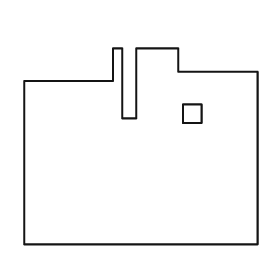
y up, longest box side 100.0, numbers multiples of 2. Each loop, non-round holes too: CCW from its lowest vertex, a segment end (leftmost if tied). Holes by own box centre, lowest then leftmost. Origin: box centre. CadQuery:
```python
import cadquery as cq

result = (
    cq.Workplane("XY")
    .moveTo(-50.0, -42.0)
    .lineTo(50.0, -42.0)
    .lineTo(50.0, 32.0)
    .lineTo(16.0, 32.0)
    .lineTo(16.0, 42.0)
    .lineTo(-2.0, 42.0)
    .lineTo(-2.0, 12.0)
    .lineTo(-8.0, 12.0)
    .lineTo(-8.0, 42.0)
    .lineTo(-12.0, 42.0)
    .lineTo(-12.0, 28.0)
    .lineTo(-50.0, 28.0)
    .close()
    .moveTo(18.0, 10.0)
    .lineTo(26.0, 10.0)
    .lineTo(26.0, 18.0)
    .lineTo(18.0, 18.0)
    .close()
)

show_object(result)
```